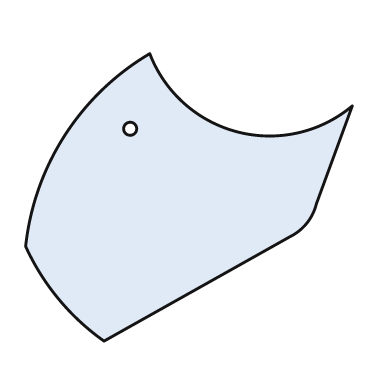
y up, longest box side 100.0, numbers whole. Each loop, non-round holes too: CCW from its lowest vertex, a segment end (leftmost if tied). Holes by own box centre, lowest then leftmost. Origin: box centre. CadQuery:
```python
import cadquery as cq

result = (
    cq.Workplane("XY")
    .moveTo(-26.0, -44.0)
    .lineTo(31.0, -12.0)
    .threePointArc((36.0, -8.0), (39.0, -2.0))
    .lineTo(50.0, 28.0)
    .threePointArc((15.0, 20.0), (-12.0, 44.0))
    .threePointArc((-38.0, 19.0), (-50.0, -15.0))
    .threePointArc((-40.0, -31.0), (-26.0, -44.0))
    .close()
    .moveTo(-18.0, 21.0)
    .circle(2.0)
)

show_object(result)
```